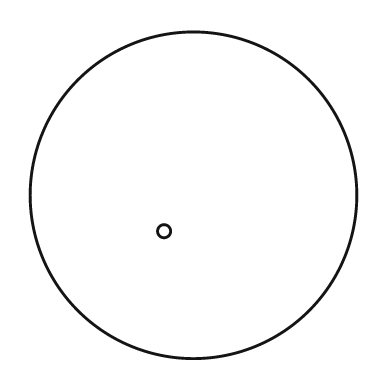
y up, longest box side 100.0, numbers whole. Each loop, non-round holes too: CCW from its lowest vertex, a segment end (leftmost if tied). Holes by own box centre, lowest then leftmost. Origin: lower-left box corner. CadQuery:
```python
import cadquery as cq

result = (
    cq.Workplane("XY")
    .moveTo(50.0, 50.0)
    .circle(50.0)
    .moveTo(41.0, 39.0)
    .circle(2.0)
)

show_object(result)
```